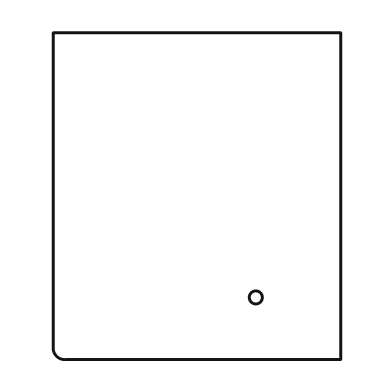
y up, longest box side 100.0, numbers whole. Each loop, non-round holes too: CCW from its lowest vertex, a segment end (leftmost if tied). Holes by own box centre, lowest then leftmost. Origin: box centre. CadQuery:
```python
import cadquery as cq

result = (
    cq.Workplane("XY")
    .moveTo(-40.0, -50.0)
    .lineTo(44.0, -50.0)
    .lineTo(44.0, 50.0)
    .lineTo(-44.0, 50.0)
    .lineTo(-44.0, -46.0)
    .threePointArc((-43.0, -49.0), (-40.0, -50.0))
    .close()
    .moveTo(18.0, -31.0)
    .circle(2.0)
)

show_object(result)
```